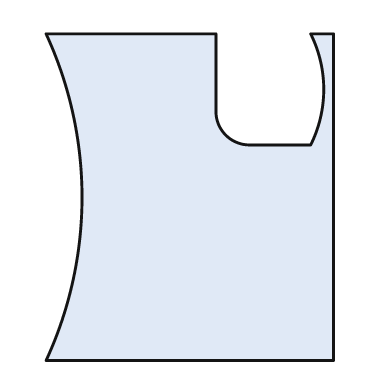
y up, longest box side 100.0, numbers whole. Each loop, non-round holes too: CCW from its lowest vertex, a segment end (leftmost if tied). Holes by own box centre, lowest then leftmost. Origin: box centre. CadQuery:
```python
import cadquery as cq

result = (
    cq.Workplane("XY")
    .moveTo(-44.0, -50.0)
    .lineTo(44.0, -50.0)
    .lineTo(44.0, 50.0)
    .lineTo(37.0, 50.0)
    .threePointArc((41.0, 33.0), (37.0, 16.0))
    .lineTo(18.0, 16.0)
    .threePointArc((11.0, 19.0), (8.0, 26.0))
    .lineTo(8.0, 50.0)
    .lineTo(-44.0, 50.0)
    .threePointArc((-33.0, 0.0), (-44.0, -50.0))
    .close()
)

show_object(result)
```